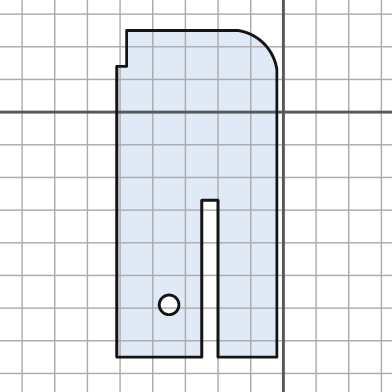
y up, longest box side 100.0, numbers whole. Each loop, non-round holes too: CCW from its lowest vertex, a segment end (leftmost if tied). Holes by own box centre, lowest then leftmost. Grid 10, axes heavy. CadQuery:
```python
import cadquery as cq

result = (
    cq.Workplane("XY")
    .moveTo(-51.0, -75.0)
    .lineTo(-25.0, -75.0)
    .lineTo(-25.0, -27.0)
    .lineTo(-20.0, -27.0)
    .lineTo(-20.0, -75.0)
    .lineTo(-2.0, -75.0)
    .lineTo(-2.0, 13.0)
    .threePointArc((-6.0, 21.0), (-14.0, 25.0))
    .lineTo(-48.0, 25.0)
    .lineTo(-48.0, 14.0)
    .lineTo(-51.0, 14.0)
    .close()
    .moveTo(-35.0, -59.0)
    .circle(3.0)
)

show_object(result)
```